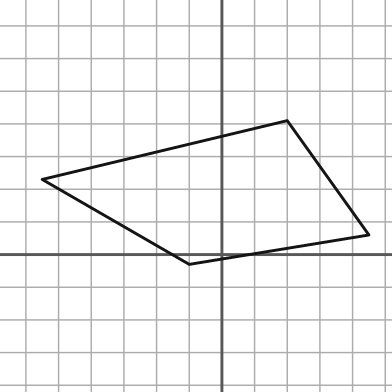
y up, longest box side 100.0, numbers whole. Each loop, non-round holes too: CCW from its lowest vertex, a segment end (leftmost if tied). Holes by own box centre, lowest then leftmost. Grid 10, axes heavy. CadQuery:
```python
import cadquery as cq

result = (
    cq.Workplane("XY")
    .moveTo(-10.0, -3.0)
    .lineTo(45.0, 6.0)
    .lineTo(20.0, 41.0)
    .lineTo(-55.0, 23.0)
    .close()
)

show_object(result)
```